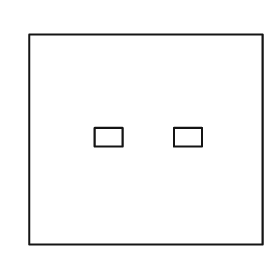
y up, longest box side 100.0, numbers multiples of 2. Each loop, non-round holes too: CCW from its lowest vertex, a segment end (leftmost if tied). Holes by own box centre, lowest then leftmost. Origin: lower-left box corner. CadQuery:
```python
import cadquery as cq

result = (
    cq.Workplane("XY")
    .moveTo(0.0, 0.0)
    .lineTo(100.0, 0.0)
    .lineTo(100.0, 90.0)
    .lineTo(0.0, 90.0)
    .close()
    .moveTo(28.0, 42.0)
    .lineTo(40.0, 42.0)
    .lineTo(40.0, 50.0)
    .lineTo(28.0, 50.0)
    .close()
    .moveTo(62.0, 42.0)
    .lineTo(74.0, 42.0)
    .lineTo(74.0, 50.0)
    .lineTo(62.0, 50.0)
    .close()
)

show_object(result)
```